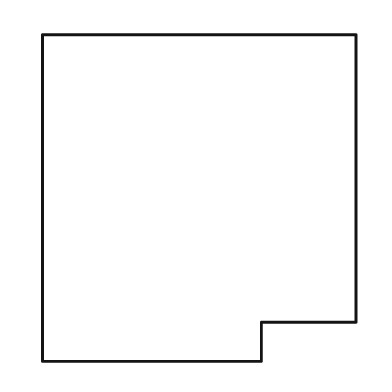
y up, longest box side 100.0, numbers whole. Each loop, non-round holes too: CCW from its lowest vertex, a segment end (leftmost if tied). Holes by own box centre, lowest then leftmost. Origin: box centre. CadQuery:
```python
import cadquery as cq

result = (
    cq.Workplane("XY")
    .moveTo(-48.0, -50.0)
    .lineTo(19.0, -50.0)
    .lineTo(19.0, -38.0)
    .lineTo(48.0, -38.0)
    .lineTo(48.0, 50.0)
    .lineTo(-48.0, 50.0)
    .close()
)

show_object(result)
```